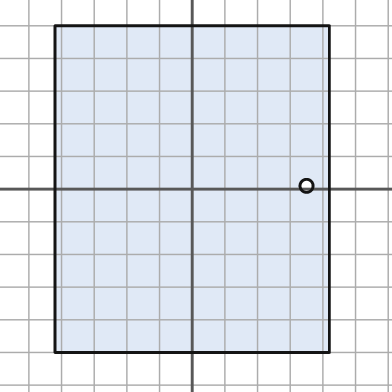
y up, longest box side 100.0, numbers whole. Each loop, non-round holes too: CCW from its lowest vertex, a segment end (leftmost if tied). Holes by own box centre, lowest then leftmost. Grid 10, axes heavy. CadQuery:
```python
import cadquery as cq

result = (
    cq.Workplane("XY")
    .moveTo(-42.0, -50.0)
    .lineTo(42.0, -50.0)
    .lineTo(42.0, 50.0)
    .lineTo(-42.0, 50.0)
    .close()
    .moveTo(35.0, 1.0)
    .circle(2.0)
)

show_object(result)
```